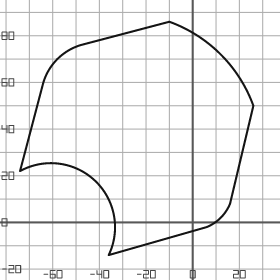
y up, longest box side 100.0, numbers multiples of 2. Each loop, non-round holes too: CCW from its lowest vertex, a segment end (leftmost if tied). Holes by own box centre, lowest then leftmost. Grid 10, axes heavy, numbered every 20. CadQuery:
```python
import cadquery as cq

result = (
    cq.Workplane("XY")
    .moveTo(-36.0, -14.0)
    .lineTo(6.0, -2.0)
    .threePointArc((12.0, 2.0), (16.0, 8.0))
    .lineTo(26.0, 50.0)
    .threePointArc((12.0, 72.0), (-10.0, 86.0))
    .lineTo(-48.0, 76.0)
    .threePointArc((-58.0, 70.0), (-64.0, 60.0))
    .lineTo(-74.0, 22.0)
    .threePointArc((-42.0, 18.0), (-36.0, -14.0))
    .close()
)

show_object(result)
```